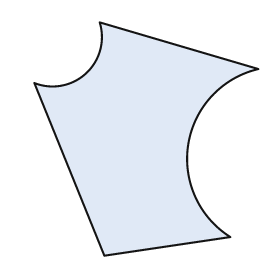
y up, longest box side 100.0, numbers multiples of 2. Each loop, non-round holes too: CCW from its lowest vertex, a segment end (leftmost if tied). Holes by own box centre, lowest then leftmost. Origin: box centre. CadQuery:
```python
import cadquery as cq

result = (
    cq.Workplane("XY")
    .moveTo(-18.0, -50.0)
    .lineTo(36.0, -42.0)
    .threePointArc((18.0, -2.0), (48.0, 30.0))
    .lineTo(-20.0, 50.0)
    .threePointArc((-26.0, 28.0), (-48.0, 24.0))
    .close()
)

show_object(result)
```